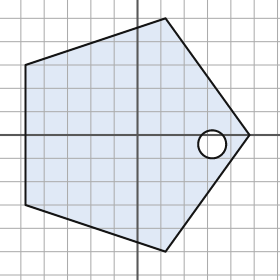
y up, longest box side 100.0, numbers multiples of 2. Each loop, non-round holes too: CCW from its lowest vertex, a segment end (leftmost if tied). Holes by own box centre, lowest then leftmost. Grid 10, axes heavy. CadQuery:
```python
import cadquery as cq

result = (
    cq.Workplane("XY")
    .moveTo(12.0, -50.0)
    .lineTo(48.0, 0.0)
    .lineTo(12.0, 50.0)
    .lineTo(-48.0, 30.0)
    .lineTo(-48.0, -30.0)
    .close()
    .moveTo(32.0, -4.0)
    .circle(6.0)
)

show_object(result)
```